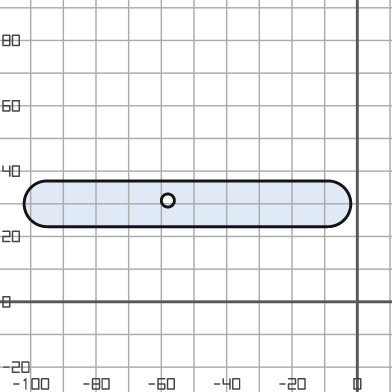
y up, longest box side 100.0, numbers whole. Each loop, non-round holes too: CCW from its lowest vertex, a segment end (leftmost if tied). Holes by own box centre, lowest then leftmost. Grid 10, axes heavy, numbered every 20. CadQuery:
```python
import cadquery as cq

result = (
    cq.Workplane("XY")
    .moveTo(-95.0, 23.0)
    .lineTo(-9.0, 23.0)
    .threePointArc((-2.0, 30.0), (-9.0, 37.0))
    .lineTo(-95.0, 37.0)
    .threePointArc((-102.0, 30.0), (-95.0, 23.0))
    .close()
    .moveTo(-58.0, 31.0)
    .circle(2.0)
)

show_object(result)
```